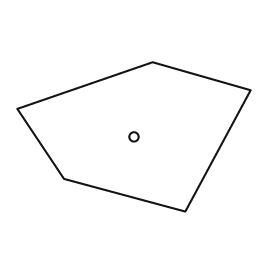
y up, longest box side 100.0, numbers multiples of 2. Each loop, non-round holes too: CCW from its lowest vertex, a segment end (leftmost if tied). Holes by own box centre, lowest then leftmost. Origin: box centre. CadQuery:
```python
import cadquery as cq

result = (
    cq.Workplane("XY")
    .moveTo(22.0, -32.0)
    .lineTo(50.0, 20.0)
    .lineTo(8.0, 32.0)
    .lineTo(-50.0, 12.0)
    .lineTo(-30.0, -18.0)
    .close()
    .moveTo(0.0, 0.0)
    .circle(2.0)
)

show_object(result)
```